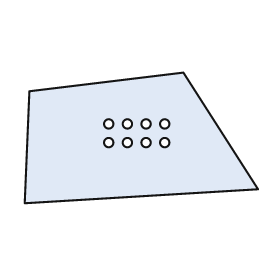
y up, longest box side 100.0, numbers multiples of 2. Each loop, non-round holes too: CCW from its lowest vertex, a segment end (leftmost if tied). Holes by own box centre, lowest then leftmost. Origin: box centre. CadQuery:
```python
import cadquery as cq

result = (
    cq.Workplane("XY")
    .moveTo(-50.0, -28.0)
    .lineTo(50.0, -22.0)
    .lineTo(18.0, 28.0)
    .lineTo(-48.0, 20.0)
    .close()
    .moveTo(-14.0, -2.0)
    .circle(2.0)
    .moveTo(-6.0, -2.0)
    .circle(2.0)
    .moveTo(2.0, -2.0)
    .circle(2.0)
    .moveTo(10.0, -2.0)
    .circle(2.0)
    .moveTo(-14.0, 6.0)
    .circle(2.0)
    .moveTo(-6.0, 6.0)
    .circle(2.0)
    .moveTo(2.0, 6.0)
    .circle(2.0)
    .moveTo(10.0, 6.0)
    .circle(2.0)
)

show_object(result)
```